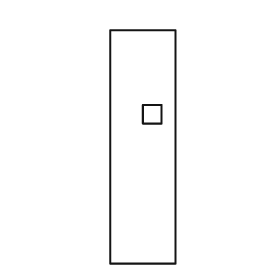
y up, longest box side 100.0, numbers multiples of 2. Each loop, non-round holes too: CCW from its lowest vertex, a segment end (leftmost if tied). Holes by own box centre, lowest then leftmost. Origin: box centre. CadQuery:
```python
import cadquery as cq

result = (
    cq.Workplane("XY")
    .moveTo(-14.0, -50.0)
    .lineTo(14.0, -50.0)
    .lineTo(14.0, 50.0)
    .lineTo(-14.0, 50.0)
    .close()
    .moveTo(0.0, 10.0)
    .lineTo(8.0, 10.0)
    .lineTo(8.0, 18.0)
    .lineTo(0.0, 18.0)
    .close()
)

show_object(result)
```